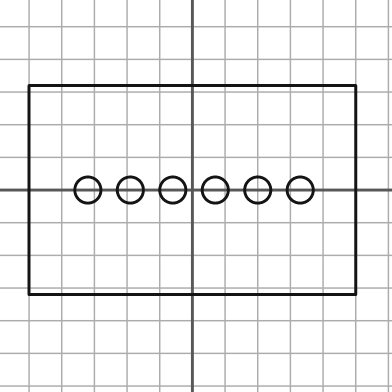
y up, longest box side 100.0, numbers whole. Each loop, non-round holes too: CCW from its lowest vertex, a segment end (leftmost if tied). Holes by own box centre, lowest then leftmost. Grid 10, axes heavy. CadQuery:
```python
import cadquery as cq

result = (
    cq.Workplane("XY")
    .moveTo(-50.0, -32.0)
    .lineTo(50.0, -32.0)
    .lineTo(50.0, 32.0)
    .lineTo(-50.0, 32.0)
    .close()
    .moveTo(-32.0, 0.0)
    .circle(4.0)
    .moveTo(-19.0, 0.0)
    .circle(4.0)
    .moveTo(-6.0, 0.0)
    .circle(4.0)
    .moveTo(7.0, 0.0)
    .circle(4.0)
    .moveTo(20.0, 0.0)
    .circle(4.0)
    .moveTo(33.0, 0.0)
    .circle(4.0)
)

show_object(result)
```